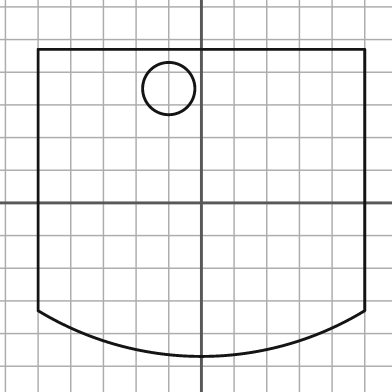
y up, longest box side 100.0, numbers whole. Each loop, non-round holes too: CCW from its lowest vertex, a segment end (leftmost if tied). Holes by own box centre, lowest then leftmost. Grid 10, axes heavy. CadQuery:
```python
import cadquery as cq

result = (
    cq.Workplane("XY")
    .moveTo(-50.0, -33.0)
    .threePointArc((0.0, -47.0), (50.0, -33.0))
    .lineTo(50.0, 47.0)
    .lineTo(-50.0, 47.0)
    .close()
    .moveTo(-10.0, 35.0)
    .circle(8.0)
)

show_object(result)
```